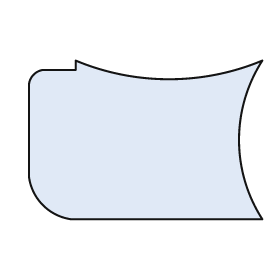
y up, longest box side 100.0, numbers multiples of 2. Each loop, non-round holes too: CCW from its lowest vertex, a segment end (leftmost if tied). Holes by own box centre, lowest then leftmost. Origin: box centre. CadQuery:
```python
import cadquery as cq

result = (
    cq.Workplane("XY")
    .moveTo(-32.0, -34.0)
    .lineTo(50.0, -34.0)
    .threePointArc((40.0, 0.0), (50.0, 34.0))
    .threePointArc((10.0, 26.0), (-30.0, 34.0))
    .lineTo(-30.0, 30.0)
    .lineTo(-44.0, 30.0)
    .threePointArc((-48.0, 28.0), (-50.0, 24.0))
    .lineTo(-50.0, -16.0)
    .threePointArc((-44.0, -28.0), (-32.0, -34.0))
    .close()
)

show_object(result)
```